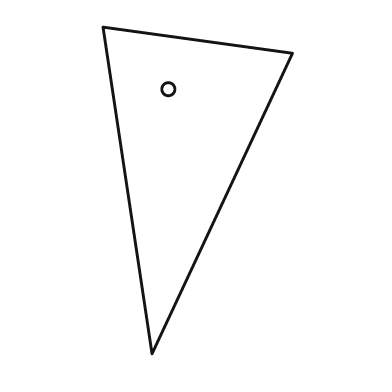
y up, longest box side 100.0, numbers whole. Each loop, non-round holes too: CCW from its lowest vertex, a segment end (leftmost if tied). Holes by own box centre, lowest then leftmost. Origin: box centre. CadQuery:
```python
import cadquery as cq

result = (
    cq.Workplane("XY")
    .moveTo(-14.0, -50.0)
    .lineTo(29.0, 42.0)
    .lineTo(-29.0, 50.0)
    .close()
    .moveTo(-9.0, 31.0)
    .circle(2.0)
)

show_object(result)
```